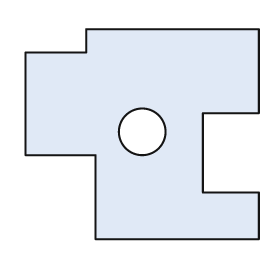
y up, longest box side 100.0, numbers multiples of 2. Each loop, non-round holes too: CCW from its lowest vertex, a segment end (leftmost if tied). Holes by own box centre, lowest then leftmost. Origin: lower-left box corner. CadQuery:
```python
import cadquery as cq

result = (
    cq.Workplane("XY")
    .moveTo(30.0, 0.0)
    .lineTo(100.0, 0.0)
    .lineTo(100.0, 20.0)
    .lineTo(76.0, 20.0)
    .lineTo(76.0, 54.0)
    .lineTo(100.0, 54.0)
    .lineTo(100.0, 90.0)
    .lineTo(26.0, 90.0)
    .lineTo(26.0, 80.0)
    .lineTo(0.0, 80.0)
    .lineTo(0.0, 36.0)
    .lineTo(30.0, 36.0)
    .close()
    .moveTo(50.0, 46.0)
    .circle(10.0)
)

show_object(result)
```